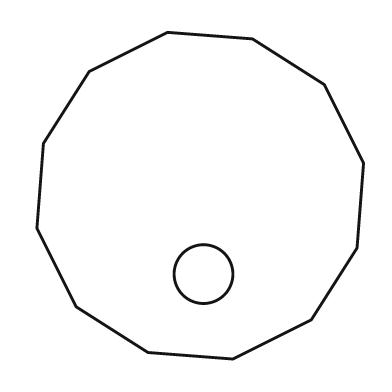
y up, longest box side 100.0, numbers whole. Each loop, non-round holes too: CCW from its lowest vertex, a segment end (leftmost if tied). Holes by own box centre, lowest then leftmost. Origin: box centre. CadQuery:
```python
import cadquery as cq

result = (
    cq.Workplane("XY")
    .moveTo(10.0, -50.0)
    .lineTo(34.0, -38.0)
    .lineTo(48.0, -16.0)
    .lineTo(50.0, 10.0)
    .lineTo(38.0, 34.0)
    .lineTo(16.0, 48.0)
    .lineTo(-10.0, 50.0)
    .lineTo(-34.0, 38.0)
    .lineTo(-48.0, 16.0)
    .lineTo(-50.0, -10.0)
    .lineTo(-38.0, -34.0)
    .lineTo(-16.0, -48.0)
    .close()
    .moveTo(1.0, -24.0)
    .circle(9.0)
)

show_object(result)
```